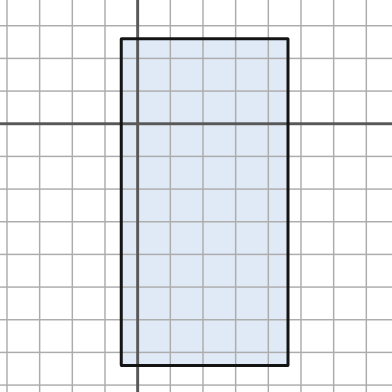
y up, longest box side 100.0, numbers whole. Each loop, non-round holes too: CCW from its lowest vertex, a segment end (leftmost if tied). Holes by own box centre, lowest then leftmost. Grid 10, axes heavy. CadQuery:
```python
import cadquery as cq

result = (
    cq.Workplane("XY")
    .moveTo(-5.0, -74.0)
    .lineTo(46.0, -74.0)
    .lineTo(46.0, 26.0)
    .lineTo(-5.0, 26.0)
    .close()
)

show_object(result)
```